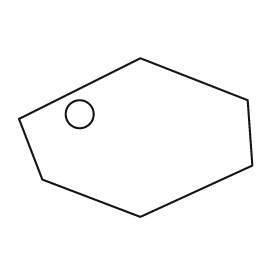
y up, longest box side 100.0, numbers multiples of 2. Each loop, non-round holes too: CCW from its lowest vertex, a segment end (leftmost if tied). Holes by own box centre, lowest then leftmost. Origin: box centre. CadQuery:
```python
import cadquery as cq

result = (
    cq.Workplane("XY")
    .moveTo(2.0, -34.0)
    .lineTo(50.0, -12.0)
    .lineTo(48.0, 16.0)
    .lineTo(2.0, 34.0)
    .lineTo(-50.0, 8.0)
    .lineTo(-40.0, -18.0)
    .close()
    .moveTo(-24.0, 10.0)
    .circle(6.0)
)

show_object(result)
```